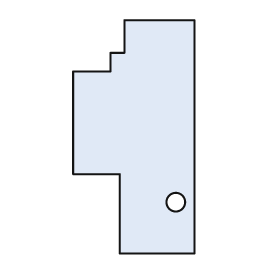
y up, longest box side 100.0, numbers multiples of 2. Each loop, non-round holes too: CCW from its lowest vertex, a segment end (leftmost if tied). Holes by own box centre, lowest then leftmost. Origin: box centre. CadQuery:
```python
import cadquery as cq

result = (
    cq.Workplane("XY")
    .moveTo(-6.0, -50.0)
    .lineTo(26.0, -50.0)
    .lineTo(26.0, 50.0)
    .lineTo(-4.0, 50.0)
    .lineTo(-4.0, 36.0)
    .lineTo(-10.0, 36.0)
    .lineTo(-10.0, 28.0)
    .lineTo(-26.0, 28.0)
    .lineTo(-26.0, -16.0)
    .lineTo(-6.0, -16.0)
    .close()
    .moveTo(18.0, -28.0)
    .circle(4.0)
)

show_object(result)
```